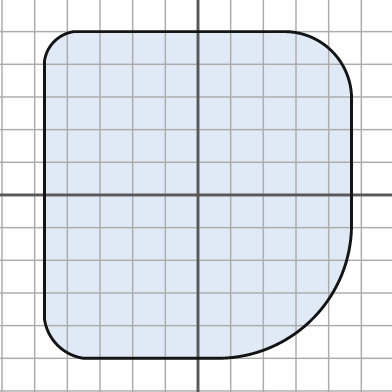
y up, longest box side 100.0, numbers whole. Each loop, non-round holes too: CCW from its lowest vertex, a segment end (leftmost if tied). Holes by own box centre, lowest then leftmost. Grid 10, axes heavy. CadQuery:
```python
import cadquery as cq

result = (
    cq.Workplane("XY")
    .moveTo(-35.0, -50.0)
    .lineTo(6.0, -50.0)
    .threePointArc((35.0, -38.0), (47.0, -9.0))
    .lineTo(47.0, 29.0)
    .threePointArc((41.0, 44.0), (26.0, 50.0))
    .lineTo(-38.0, 50.0)
    .threePointArc((-44.0, 47.0), (-47.0, 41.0))
    .lineTo(-47.0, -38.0)
    .threePointArc((-43.0, -46.0), (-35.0, -50.0))
    .close()
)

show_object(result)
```